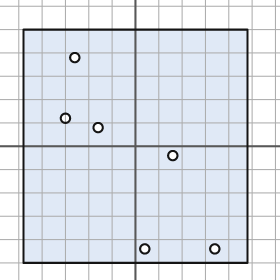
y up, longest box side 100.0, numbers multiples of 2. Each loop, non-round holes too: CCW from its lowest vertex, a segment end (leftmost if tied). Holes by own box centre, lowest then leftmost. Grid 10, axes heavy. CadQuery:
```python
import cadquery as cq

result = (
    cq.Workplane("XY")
    .moveTo(-48.0, -50.0)
    .lineTo(48.0, -50.0)
    .lineTo(48.0, 50.0)
    .lineTo(-48.0, 50.0)
    .close()
    .moveTo(4.0, -44.0)
    .circle(2.0)
    .moveTo(34.0, -44.0)
    .circle(2.0)
    .moveTo(16.0, -4.0)
    .circle(2.0)
    .moveTo(-16.0, 8.0)
    .circle(2.0)
    .moveTo(-30.0, 12.0)
    .circle(2.0)
    .moveTo(-26.0, 38.0)
    .circle(2.0)
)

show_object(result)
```